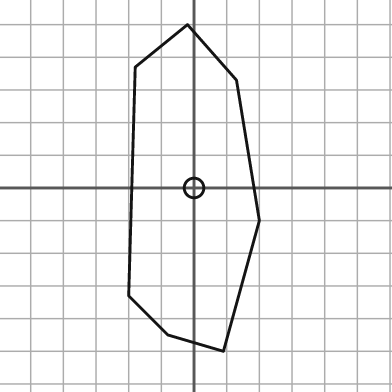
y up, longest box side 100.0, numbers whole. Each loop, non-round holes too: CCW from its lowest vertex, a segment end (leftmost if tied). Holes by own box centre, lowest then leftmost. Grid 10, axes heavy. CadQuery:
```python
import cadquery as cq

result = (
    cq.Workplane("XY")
    .moveTo(9.0, -50.0)
    .lineTo(20.0, -10.0)
    .lineTo(13.0, 33.0)
    .lineTo(-2.0, 50.0)
    .lineTo(-18.0, 37.0)
    .lineTo(-20.0, -33.0)
    .lineTo(-8.0, -45.0)
    .close()
    .moveTo(0.0, 0.0)
    .circle(3.0)
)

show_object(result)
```